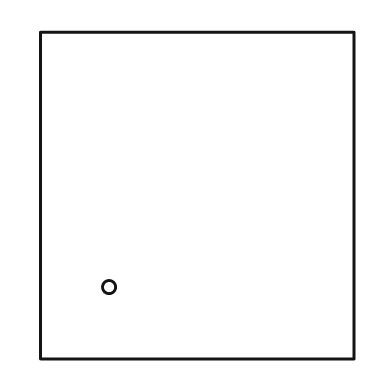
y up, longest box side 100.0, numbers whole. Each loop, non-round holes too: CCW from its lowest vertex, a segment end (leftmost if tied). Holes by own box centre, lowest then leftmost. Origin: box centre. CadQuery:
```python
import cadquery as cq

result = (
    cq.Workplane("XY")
    .moveTo(-48.0, -50.0)
    .lineTo(48.0, -50.0)
    .lineTo(48.0, 50.0)
    .lineTo(-48.0, 50.0)
    .close()
    .moveTo(-27.0, -28.0)
    .circle(2.0)
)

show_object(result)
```